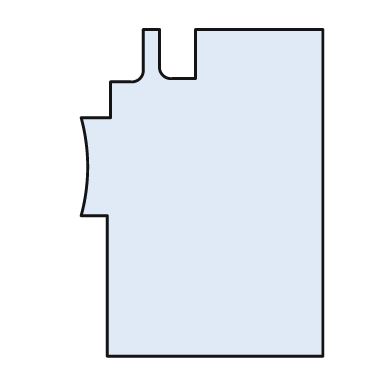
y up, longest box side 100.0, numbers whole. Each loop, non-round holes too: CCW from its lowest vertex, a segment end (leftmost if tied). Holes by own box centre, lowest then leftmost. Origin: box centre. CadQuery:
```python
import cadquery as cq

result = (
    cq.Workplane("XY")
    .moveTo(-29.0, -50.0)
    .lineTo(37.0, -50.0)
    .lineTo(37.0, 50.0)
    .lineTo(-2.0, 50.0)
    .lineTo(-2.0, 35.0)
    .lineTo(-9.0, 35.0)
    .threePointArc((-12.0, 36.0), (-13.0, 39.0))
    .lineTo(-13.0, 50.0)
    .lineTo(-18.0, 50.0)
    .lineTo(-18.0, 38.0)
    .threePointArc((-19.0, 35.0), (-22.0, 34.0))
    .lineTo(-28.0, 34.0)
    .lineTo(-28.0, 23.0)
    .lineTo(-37.0, 23.0)
    .threePointArc((-35.0, 8.0), (-37.0, -7.0))
    .lineTo(-29.0, -7.0)
    .close()
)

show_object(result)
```